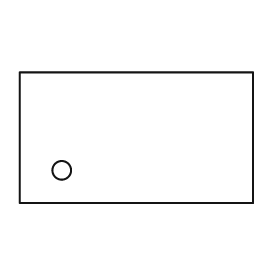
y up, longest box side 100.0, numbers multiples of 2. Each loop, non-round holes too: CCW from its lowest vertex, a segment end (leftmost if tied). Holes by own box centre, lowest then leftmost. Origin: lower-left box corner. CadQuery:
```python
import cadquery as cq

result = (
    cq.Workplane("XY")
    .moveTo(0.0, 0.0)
    .lineTo(100.0, 0.0)
    .lineTo(100.0, 56.0)
    .lineTo(0.0, 56.0)
    .close()
    .moveTo(18.0, 14.0)
    .circle(4.0)
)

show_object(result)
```